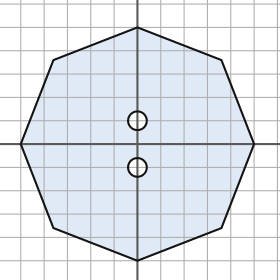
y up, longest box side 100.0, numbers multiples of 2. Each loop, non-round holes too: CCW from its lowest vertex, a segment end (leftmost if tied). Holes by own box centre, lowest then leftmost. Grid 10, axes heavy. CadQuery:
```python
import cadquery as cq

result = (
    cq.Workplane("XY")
    .moveTo(0.0, -50.0)
    .lineTo(36.0, -36.0)
    .lineTo(50.0, 0.0)
    .lineTo(36.0, 36.0)
    .lineTo(0.0, 50.0)
    .lineTo(-36.0, 36.0)
    .lineTo(-50.0, 0.0)
    .lineTo(-36.0, -36.0)
    .close()
    .moveTo(0.0, -10.0)
    .circle(4.0)
    .moveTo(0.0, 10.0)
    .circle(4.0)
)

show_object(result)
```